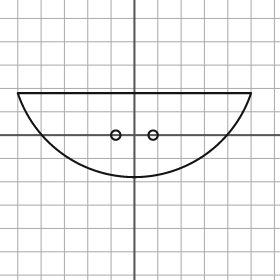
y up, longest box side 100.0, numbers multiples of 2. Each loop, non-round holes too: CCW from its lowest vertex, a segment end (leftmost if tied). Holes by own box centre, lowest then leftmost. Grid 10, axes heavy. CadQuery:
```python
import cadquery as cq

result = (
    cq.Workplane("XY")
    .moveTo(-50.0, 18.0)
    .threePointArc((0.0, -18.0), (50.0, 18.0))
    .close()
    .moveTo(-8.0, 0.0)
    .circle(2.0)
    .moveTo(8.0, 0.0)
    .circle(2.0)
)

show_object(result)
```